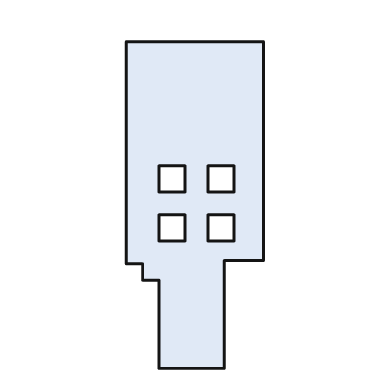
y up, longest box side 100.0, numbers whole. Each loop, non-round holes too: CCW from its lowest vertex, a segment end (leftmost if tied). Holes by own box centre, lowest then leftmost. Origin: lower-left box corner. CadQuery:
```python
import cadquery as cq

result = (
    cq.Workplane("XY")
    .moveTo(10.0, 0.0)
    .lineTo(30.0, 0.0)
    .lineTo(30.0, 33.0)
    .lineTo(42.0, 33.0)
    .lineTo(42.0, 100.0)
    .lineTo(0.0, 100.0)
    .lineTo(0.0, 32.0)
    .lineTo(5.0, 32.0)
    .lineTo(5.0, 27.0)
    .lineTo(10.0, 27.0)
    .close()
    .moveTo(10.0, 39.0)
    .lineTo(18.0, 39.0)
    .lineTo(18.0, 47.0)
    .lineTo(10.0, 47.0)
    .close()
    .moveTo(25.0, 39.0)
    .lineTo(33.0, 39.0)
    .lineTo(33.0, 47.0)
    .lineTo(25.0, 47.0)
    .close()
    .moveTo(10.0, 54.0)
    .lineTo(18.0, 54.0)
    .lineTo(18.0, 62.0)
    .lineTo(10.0, 62.0)
    .close()
    .moveTo(25.0, 54.0)
    .lineTo(33.0, 54.0)
    .lineTo(33.0, 62.0)
    .lineTo(25.0, 62.0)
    .close()
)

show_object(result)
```